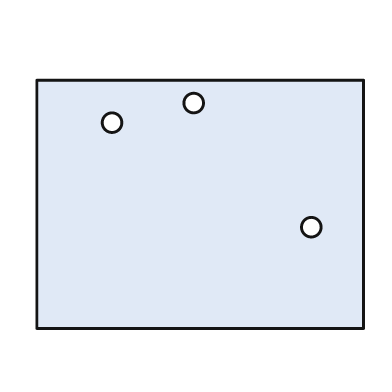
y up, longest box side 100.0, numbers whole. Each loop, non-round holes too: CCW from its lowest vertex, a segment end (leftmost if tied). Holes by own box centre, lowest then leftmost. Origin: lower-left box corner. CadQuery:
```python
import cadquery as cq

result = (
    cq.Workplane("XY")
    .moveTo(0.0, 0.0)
    .lineTo(100.0, 0.0)
    .lineTo(100.0, 76.0)
    .lineTo(0.0, 76.0)
    .close()
    .moveTo(84.0, 31.0)
    .circle(3.0)
    .moveTo(23.0, 63.0)
    .circle(3.0)
    .moveTo(48.0, 69.0)
    .circle(3.0)
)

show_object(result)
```